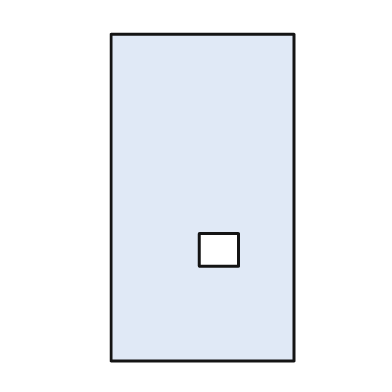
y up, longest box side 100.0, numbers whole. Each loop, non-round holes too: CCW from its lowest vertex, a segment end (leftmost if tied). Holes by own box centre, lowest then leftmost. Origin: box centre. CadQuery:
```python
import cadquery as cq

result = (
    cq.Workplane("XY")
    .moveTo(-28.0, -50.0)
    .lineTo(28.0, -50.0)
    .lineTo(28.0, 50.0)
    .lineTo(-28.0, 50.0)
    .close()
    .moveTo(-1.0, -21.0)
    .lineTo(11.0, -21.0)
    .lineTo(11.0, -11.0)
    .lineTo(-1.0, -11.0)
    .close()
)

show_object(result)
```